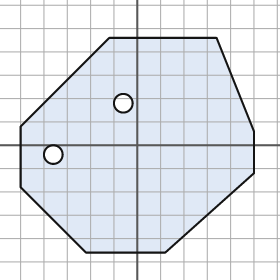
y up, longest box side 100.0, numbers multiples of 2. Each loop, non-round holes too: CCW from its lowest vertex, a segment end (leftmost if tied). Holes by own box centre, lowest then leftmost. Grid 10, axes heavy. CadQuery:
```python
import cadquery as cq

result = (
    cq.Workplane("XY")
    .moveTo(-22.0, -46.0)
    .lineTo(12.0, -46.0)
    .lineTo(50.0, -12.0)
    .lineTo(50.0, 6.0)
    .lineTo(34.0, 46.0)
    .lineTo(-12.0, 46.0)
    .lineTo(-50.0, 8.0)
    .lineTo(-50.0, -18.0)
    .close()
    .moveTo(-36.0, -4.0)
    .circle(4.0)
    .moveTo(-6.0, 18.0)
    .circle(4.0)
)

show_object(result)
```